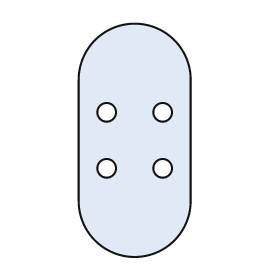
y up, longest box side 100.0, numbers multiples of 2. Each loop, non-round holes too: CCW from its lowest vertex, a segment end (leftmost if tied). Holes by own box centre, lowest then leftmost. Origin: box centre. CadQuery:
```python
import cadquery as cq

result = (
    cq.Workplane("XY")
    .moveTo(-24.0, -26.0)
    .threePointArc((0.0, -50.0), (24.0, -26.0))
    .lineTo(24.0, 26.0)
    .threePointArc((0.0, 50.0), (-24.0, 26.0))
    .close()
    .moveTo(-12.0, -12.0)
    .circle(4.0)
    .moveTo(12.0, -12.0)
    .circle(4.0)
    .moveTo(-12.0, 12.0)
    .circle(4.0)
    .moveTo(12.0, 12.0)
    .circle(4.0)
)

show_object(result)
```